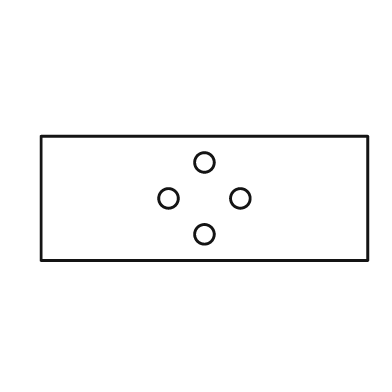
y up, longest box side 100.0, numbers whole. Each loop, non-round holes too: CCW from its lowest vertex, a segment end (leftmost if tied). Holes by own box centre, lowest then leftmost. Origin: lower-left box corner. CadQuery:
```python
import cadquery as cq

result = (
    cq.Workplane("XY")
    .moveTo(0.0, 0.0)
    .lineTo(100.0, 0.0)
    .lineTo(100.0, 38.0)
    .lineTo(0.0, 38.0)
    .close()
    .moveTo(50.0, 8.0)
    .circle(3.0)
    .moveTo(39.0, 19.0)
    .circle(3.0)
    .moveTo(61.0, 19.0)
    .circle(3.0)
    .moveTo(50.0, 30.0)
    .circle(3.0)
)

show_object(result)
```